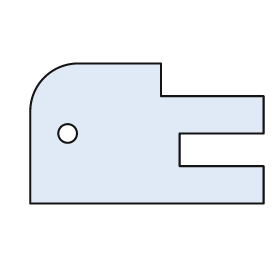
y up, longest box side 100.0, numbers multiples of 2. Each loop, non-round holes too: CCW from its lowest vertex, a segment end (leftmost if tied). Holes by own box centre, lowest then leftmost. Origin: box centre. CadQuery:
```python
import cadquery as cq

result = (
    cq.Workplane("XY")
    .moveTo(-50.0, -30.0)
    .lineTo(50.0, -30.0)
    .lineTo(50.0, -14.0)
    .lineTo(14.0, -14.0)
    .lineTo(14.0, 0.0)
    .lineTo(50.0, 0.0)
    .lineTo(50.0, 16.0)
    .lineTo(6.0, 16.0)
    .lineTo(6.0, 30.0)
    .lineTo(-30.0, 30.0)
    .threePointArc((-44.0, 24.0), (-50.0, 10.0))
    .close()
    .moveTo(-34.0, 0.0)
    .circle(4.0)
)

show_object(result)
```